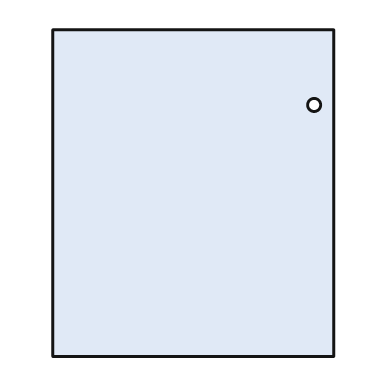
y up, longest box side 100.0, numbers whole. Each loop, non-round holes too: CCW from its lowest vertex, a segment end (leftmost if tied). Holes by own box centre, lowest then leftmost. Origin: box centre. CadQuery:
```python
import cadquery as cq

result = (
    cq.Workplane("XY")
    .moveTo(-43.0, -50.0)
    .lineTo(43.0, -50.0)
    .lineTo(43.0, 50.0)
    .lineTo(-43.0, 50.0)
    .close()
    .moveTo(37.0, 27.0)
    .circle(2.0)
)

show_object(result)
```